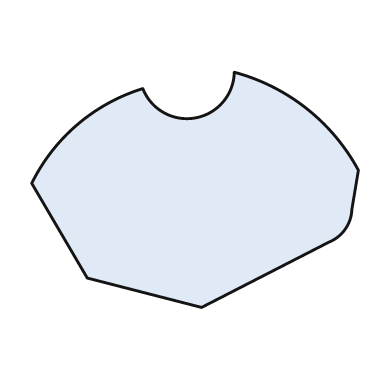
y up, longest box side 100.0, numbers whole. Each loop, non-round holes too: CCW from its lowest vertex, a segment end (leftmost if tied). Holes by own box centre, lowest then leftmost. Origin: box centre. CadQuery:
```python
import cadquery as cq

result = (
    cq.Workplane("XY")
    .moveTo(2.0, -36.0)
    .lineTo(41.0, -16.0)
    .threePointArc((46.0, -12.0), (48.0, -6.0))
    .lineTo(50.0, 6.0)
    .threePointArc((34.0, 25.0), (12.0, 36.0))
    .threePointArc((0.0, 22.0), (-16.0, 31.0))
    .threePointArc((-36.0, 20.0), (-50.0, 2.0))
    .lineTo(-33.0, -27.0)
    .close()
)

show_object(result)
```